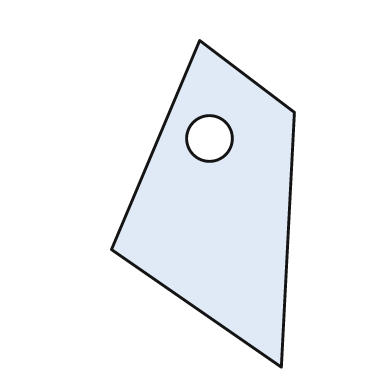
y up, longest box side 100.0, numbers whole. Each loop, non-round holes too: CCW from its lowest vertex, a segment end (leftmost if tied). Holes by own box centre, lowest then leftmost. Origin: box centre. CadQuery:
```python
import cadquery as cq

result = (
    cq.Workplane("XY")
    .moveTo(24.0, -50.0)
    .lineTo(28.0, 28.0)
    .lineTo(-1.0, 50.0)
    .lineTo(-28.0, -14.0)
    .close()
    .moveTo(2.0, 20.0)
    .circle(7.0)
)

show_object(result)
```